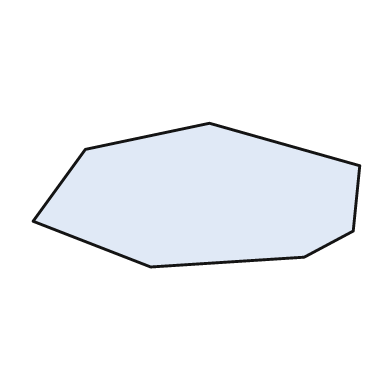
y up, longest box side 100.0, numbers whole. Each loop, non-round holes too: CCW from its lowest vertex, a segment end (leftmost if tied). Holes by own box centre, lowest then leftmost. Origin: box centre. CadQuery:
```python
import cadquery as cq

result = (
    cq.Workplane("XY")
    .moveTo(-14.0, -22.0)
    .lineTo(33.0, -19.0)
    .lineTo(48.0, -11.0)
    .lineTo(50.0, 9.0)
    .lineTo(4.0, 22.0)
    .lineTo(-34.0, 14.0)
    .lineTo(-50.0, -8.0)
    .close()
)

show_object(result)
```